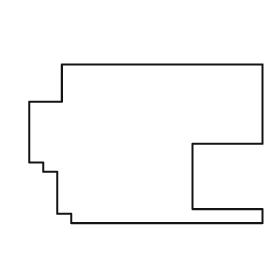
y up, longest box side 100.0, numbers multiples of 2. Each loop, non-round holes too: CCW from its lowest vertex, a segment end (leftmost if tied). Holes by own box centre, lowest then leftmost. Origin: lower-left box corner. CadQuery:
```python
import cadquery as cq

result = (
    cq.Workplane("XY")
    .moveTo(18.0, 0.0)
    .lineTo(100.0, 0.0)
    .lineTo(100.0, 6.0)
    .lineTo(70.0, 6.0)
    .lineTo(70.0, 34.0)
    .lineTo(100.0, 34.0)
    .lineTo(100.0, 68.0)
    .lineTo(14.0, 68.0)
    .lineTo(14.0, 52.0)
    .lineTo(0.0, 52.0)
    .lineTo(0.0, 26.0)
    .lineTo(6.0, 26.0)
    .lineTo(6.0, 22.0)
    .lineTo(12.0, 22.0)
    .lineTo(12.0, 4.0)
    .lineTo(18.0, 4.0)
    .close()
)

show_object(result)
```